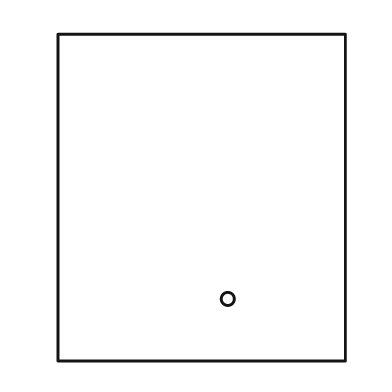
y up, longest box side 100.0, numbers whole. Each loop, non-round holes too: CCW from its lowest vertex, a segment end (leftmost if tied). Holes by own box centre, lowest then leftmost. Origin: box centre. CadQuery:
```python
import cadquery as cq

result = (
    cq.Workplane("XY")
    .moveTo(-44.0, -50.0)
    .lineTo(44.0, -50.0)
    .lineTo(44.0, 50.0)
    .lineTo(-44.0, 50.0)
    .close()
    .moveTo(8.0, -31.0)
    .circle(2.0)
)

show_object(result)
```